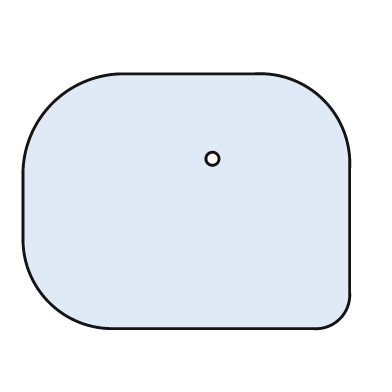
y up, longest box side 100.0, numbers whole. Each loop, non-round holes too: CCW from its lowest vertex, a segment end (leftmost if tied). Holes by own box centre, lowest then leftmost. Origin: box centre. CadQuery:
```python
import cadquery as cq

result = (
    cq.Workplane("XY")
    .moveTo(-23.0, -39.0)
    .lineTo(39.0, -39.0)
    .threePointArc((47.0, -36.0), (50.0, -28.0))
    .lineTo(50.0, 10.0)
    .threePointArc((42.0, 31.0), (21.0, 39.0))
    .lineTo(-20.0, 39.0)
    .threePointArc((-41.0, 30.0), (-50.0, 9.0))
    .lineTo(-50.0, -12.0)
    .threePointArc((-42.0, -31.0), (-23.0, -39.0))
    .close()
    .moveTo(8.0, 13.0)
    .circle(2.0)
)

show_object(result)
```